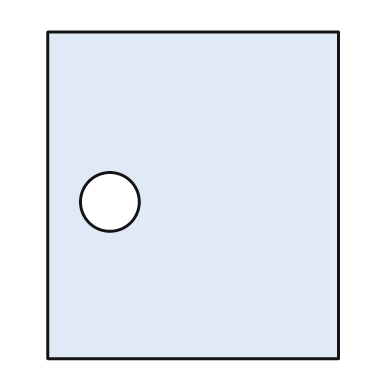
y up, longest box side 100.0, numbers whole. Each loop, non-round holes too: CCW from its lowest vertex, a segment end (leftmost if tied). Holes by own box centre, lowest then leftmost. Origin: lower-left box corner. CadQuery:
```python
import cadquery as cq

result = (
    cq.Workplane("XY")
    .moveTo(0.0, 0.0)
    .lineTo(89.0, 0.0)
    .lineTo(89.0, 100.0)
    .lineTo(0.0, 100.0)
    .close()
    .moveTo(19.0, 48.0)
    .circle(9.0)
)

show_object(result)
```